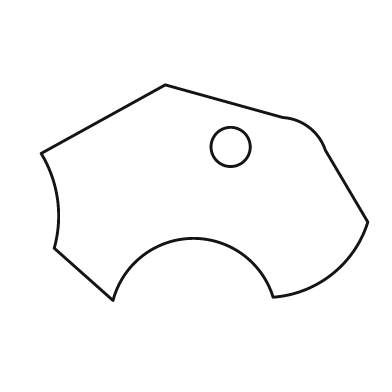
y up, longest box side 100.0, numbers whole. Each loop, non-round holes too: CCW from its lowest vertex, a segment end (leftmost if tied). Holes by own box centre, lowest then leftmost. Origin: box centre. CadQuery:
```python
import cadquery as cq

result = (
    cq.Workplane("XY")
    .moveTo(-28.0, -33.0)
    .threePointArc((-4.0, -14.0), (21.0, -32.0))
    .threePointArc((39.0, -25.0), (50.0, -9.0))
    .lineTo(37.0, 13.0)
    .threePointArc((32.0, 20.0), (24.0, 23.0))
    .lineTo(-12.0, 33.0)
    .lineTo(-50.0, 12.0)
    .threePointArc((-45.0, -2.0), (-46.0, -17.0))
    .close()
    .moveTo(8.0, 14.0)
    .circle(6.0)
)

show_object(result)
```